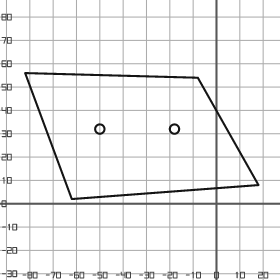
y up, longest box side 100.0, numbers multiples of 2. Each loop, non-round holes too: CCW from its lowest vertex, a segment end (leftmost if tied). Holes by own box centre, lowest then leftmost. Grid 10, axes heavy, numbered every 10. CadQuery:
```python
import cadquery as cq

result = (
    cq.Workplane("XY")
    .moveTo(-62.0, 2.0)
    .lineTo(18.0, 8.0)
    .lineTo(-8.0, 54.0)
    .lineTo(-82.0, 56.0)
    .close()
    .moveTo(-50.0, 32.0)
    .circle(2.0)
    .moveTo(-18.0, 32.0)
    .circle(2.0)
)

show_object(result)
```